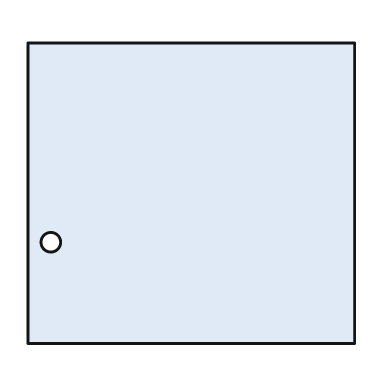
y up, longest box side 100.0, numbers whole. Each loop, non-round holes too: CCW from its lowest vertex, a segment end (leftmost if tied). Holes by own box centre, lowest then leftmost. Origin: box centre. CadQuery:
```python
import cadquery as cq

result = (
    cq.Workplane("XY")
    .moveTo(-50.0, -46.0)
    .lineTo(50.0, -46.0)
    .lineTo(50.0, 46.0)
    .lineTo(-50.0, 46.0)
    .close()
    .moveTo(-43.0, -15.0)
    .circle(3.0)
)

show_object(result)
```